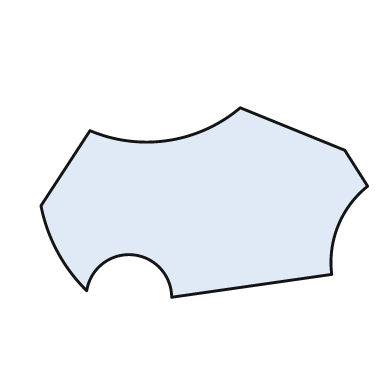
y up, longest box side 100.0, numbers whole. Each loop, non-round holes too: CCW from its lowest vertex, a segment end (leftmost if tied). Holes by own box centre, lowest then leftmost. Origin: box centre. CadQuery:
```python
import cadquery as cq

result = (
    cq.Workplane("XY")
    .moveTo(-10.0, -29.0)
    .lineTo(39.0, -22.0)
    .threePointArc((41.0, -7.0), (50.0, 5.0))
    .lineTo(43.0, 16.0)
    .lineTo(11.0, 29.0)
    .threePointArc((-11.0, 19.0), (-35.0, 22.0))
    .lineTo(-50.0, -1.0)
    .threePointArc((-45.0, -15.0), (-36.0, -27.0))
    .threePointArc((-22.0, -16.0), (-10.0, -29.0))
    .close()
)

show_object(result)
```